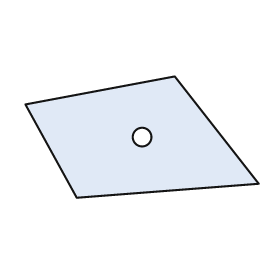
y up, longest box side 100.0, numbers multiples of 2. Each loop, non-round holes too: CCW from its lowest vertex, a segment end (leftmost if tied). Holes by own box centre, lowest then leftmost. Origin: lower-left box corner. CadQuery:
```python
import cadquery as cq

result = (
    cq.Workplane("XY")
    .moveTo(22.0, 0.0)
    .lineTo(100.0, 6.0)
    .lineTo(64.0, 52.0)
    .lineTo(0.0, 40.0)
    .close()
    .moveTo(50.0, 26.0)
    .circle(4.0)
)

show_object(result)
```